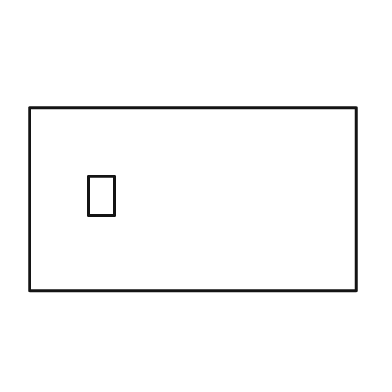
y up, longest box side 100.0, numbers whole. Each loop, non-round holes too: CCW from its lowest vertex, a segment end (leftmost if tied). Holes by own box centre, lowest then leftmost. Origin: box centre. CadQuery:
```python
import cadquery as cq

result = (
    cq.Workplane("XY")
    .moveTo(-50.0, -28.0)
    .lineTo(50.0, -28.0)
    .lineTo(50.0, 28.0)
    .lineTo(-50.0, 28.0)
    .close()
    .moveTo(-32.0, -5.0)
    .lineTo(-24.0, -5.0)
    .lineTo(-24.0, 7.0)
    .lineTo(-32.0, 7.0)
    .close()
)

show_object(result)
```